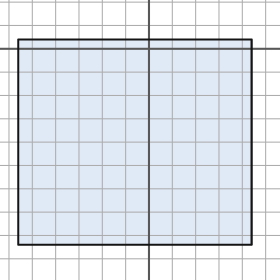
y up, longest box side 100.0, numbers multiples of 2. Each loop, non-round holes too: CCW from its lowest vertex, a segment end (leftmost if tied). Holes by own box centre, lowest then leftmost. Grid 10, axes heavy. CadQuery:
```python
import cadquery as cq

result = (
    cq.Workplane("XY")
    .moveTo(-56.0, -84.0)
    .lineTo(44.0, -84.0)
    .lineTo(44.0, 4.0)
    .lineTo(-56.0, 4.0)
    .close()
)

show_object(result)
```